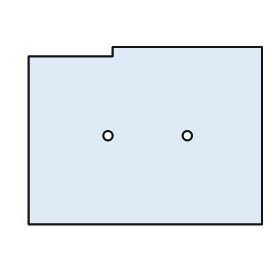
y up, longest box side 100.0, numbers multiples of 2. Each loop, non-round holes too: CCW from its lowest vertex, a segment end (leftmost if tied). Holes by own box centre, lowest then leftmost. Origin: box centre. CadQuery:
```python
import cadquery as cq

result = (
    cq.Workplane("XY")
    .moveTo(-50.0, -38.0)
    .lineTo(50.0, -38.0)
    .lineTo(50.0, 38.0)
    .lineTo(-14.0, 38.0)
    .lineTo(-14.0, 34.0)
    .lineTo(-50.0, 34.0)
    .close()
    .moveTo(-16.0, 0.0)
    .circle(2.0)
    .moveTo(18.0, 0.0)
    .circle(2.0)
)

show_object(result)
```